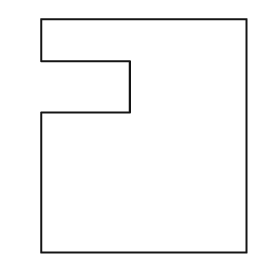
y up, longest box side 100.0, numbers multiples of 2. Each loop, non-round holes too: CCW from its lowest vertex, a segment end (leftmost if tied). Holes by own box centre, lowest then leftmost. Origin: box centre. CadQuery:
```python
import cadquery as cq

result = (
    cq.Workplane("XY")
    .moveTo(-44.0, -50.0)
    .lineTo(44.0, -50.0)
    .lineTo(44.0, 50.0)
    .lineTo(-44.0, 50.0)
    .lineTo(-44.0, 32.0)
    .lineTo(-6.0, 32.0)
    .lineTo(-6.0, 10.0)
    .lineTo(-44.0, 10.0)
    .close()
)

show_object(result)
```